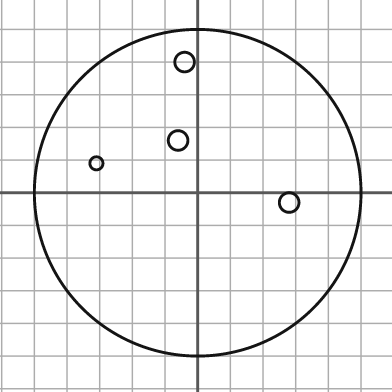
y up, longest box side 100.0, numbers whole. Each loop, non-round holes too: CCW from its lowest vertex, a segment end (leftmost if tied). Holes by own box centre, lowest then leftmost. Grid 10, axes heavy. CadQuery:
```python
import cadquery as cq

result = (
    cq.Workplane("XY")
    .moveTo(0.0, 0.0)
    .circle(50.0)
    .moveTo(28.0, -3.0)
    .circle(3.0)
    .moveTo(-31.0, 9.0)
    .circle(2.0)
    .moveTo(-6.0, 16.0)
    .circle(3.0)
    .moveTo(-4.0, 40.0)
    .circle(3.0)
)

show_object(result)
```